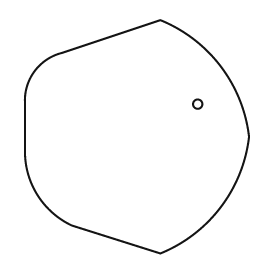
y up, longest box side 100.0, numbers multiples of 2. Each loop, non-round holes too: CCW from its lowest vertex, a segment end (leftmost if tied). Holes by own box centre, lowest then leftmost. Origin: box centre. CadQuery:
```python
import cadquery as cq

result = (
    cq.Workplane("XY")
    .moveTo(10.0, -50.0)
    .threePointArc((36.0, -30.0), (48.0, 0.0))
    .threePointArc((36.0, 30.0), (10.0, 50.0))
    .lineTo(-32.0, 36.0)
    .threePointArc((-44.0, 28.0), (-48.0, 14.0))
    .lineTo(-48.0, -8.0)
    .threePointArc((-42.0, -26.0), (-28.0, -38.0))
    .close()
    .moveTo(26.0, 14.0)
    .circle(2.0)
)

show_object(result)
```